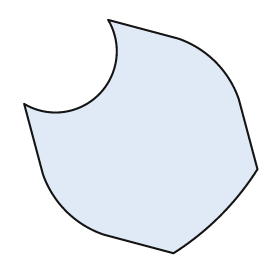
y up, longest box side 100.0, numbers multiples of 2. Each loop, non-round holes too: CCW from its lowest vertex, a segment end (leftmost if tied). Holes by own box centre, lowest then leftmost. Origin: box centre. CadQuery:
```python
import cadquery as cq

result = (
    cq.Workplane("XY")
    .moveTo(14.0, -50.0)
    .threePointArc((34.0, -34.0), (50.0, -14.0))
    .lineTo(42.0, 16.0)
    .threePointArc((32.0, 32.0), (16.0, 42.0))
    .lineTo(-14.0, 50.0)
    .threePointArc((-18.0, 18.0), (-50.0, 14.0))
    .lineTo(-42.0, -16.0)
    .threePointArc((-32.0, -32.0), (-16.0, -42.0))
    .close()
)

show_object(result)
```